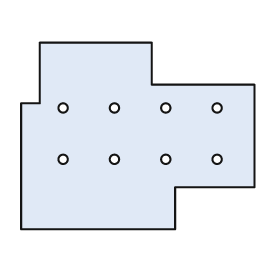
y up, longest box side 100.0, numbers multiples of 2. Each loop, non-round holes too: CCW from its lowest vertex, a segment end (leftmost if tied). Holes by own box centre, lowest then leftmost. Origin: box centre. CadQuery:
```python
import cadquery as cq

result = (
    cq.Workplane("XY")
    .moveTo(-50.0, -40.0)
    .lineTo(16.0, -40.0)
    .lineTo(16.0, -22.0)
    .lineTo(50.0, -22.0)
    .lineTo(50.0, 22.0)
    .lineTo(6.0, 22.0)
    .lineTo(6.0, 40.0)
    .lineTo(-42.0, 40.0)
    .lineTo(-42.0, 14.0)
    .lineTo(-50.0, 14.0)
    .close()
    .moveTo(-32.0, -10.0)
    .circle(2.0)
    .moveTo(-10.0, -10.0)
    .circle(2.0)
    .moveTo(12.0, -10.0)
    .circle(2.0)
    .moveTo(34.0, -10.0)
    .circle(2.0)
    .moveTo(-32.0, 12.0)
    .circle(2.0)
    .moveTo(-10.0, 12.0)
    .circle(2.0)
    .moveTo(12.0, 12.0)
    .circle(2.0)
    .moveTo(34.0, 12.0)
    .circle(2.0)
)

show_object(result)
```